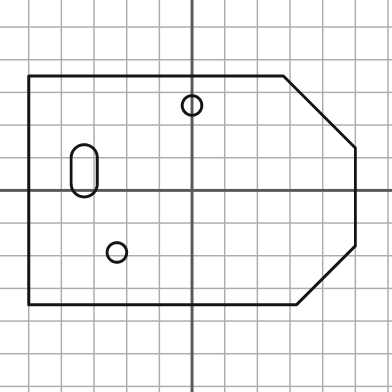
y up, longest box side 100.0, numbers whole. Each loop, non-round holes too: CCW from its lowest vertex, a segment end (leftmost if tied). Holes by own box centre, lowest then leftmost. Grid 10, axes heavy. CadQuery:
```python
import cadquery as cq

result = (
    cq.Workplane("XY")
    .moveTo(-50.0, -35.0)
    .lineTo(32.0, -35.0)
    .lineTo(50.0, -17.0)
    .lineTo(50.0, 13.0)
    .lineTo(28.0, 35.0)
    .lineTo(-50.0, 35.0)
    .close()
    .moveTo(-23.0, -19.0)
    .circle(3.0)
    .moveTo(-37.0, 2.0)
    .threePointArc((-33.0, -2.0), (-29.0, 2.0))
    .lineTo(-29.0, 10.0)
    .threePointArc((-33.0, 14.0), (-37.0, 10.0))
    .close()
    .moveTo(0.0, 26.0)
    .circle(3.0)
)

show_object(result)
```